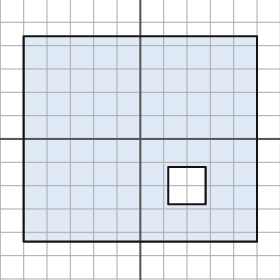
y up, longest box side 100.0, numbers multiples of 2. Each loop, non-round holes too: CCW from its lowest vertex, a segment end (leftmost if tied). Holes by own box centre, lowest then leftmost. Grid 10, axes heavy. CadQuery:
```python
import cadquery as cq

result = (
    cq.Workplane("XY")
    .moveTo(-50.0, -44.0)
    .lineTo(50.0, -44.0)
    .lineTo(50.0, 44.0)
    .lineTo(-50.0, 44.0)
    .close()
    .moveTo(12.0, -28.0)
    .lineTo(28.0, -28.0)
    .lineTo(28.0, -12.0)
    .lineTo(12.0, -12.0)
    .close()
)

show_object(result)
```